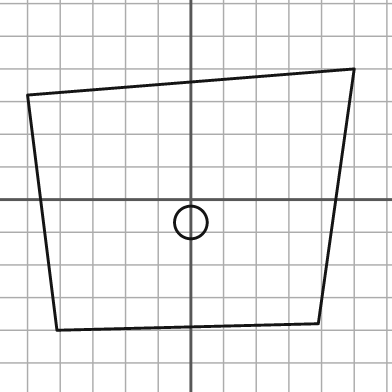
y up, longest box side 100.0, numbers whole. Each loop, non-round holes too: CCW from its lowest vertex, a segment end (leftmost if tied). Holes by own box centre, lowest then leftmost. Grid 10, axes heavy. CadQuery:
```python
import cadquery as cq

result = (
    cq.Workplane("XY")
    .moveTo(-41.0, -40.0)
    .lineTo(39.0, -38.0)
    .lineTo(50.0, 40.0)
    .lineTo(-50.0, 32.0)
    .close()
    .moveTo(0.0, -7.0)
    .circle(5.0)
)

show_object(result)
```